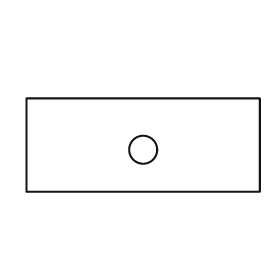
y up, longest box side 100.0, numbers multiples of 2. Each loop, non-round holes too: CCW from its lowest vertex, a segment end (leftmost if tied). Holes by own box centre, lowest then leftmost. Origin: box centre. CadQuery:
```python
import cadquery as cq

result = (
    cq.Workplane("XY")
    .moveTo(-50.0, -20.0)
    .lineTo(50.0, -20.0)
    .lineTo(50.0, 20.0)
    .lineTo(-50.0, 20.0)
    .close()
    .moveTo(0.0, -2.0)
    .circle(6.0)
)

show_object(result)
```